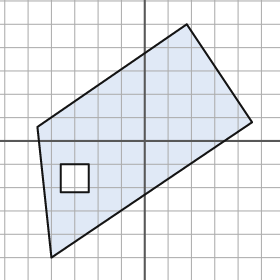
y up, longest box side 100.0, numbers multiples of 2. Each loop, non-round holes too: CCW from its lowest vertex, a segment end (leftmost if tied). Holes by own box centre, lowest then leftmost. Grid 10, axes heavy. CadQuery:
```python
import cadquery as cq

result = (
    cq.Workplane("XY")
    .moveTo(-40.0, -50.0)
    .lineTo(46.0, 8.0)
    .lineTo(18.0, 50.0)
    .lineTo(-46.0, 6.0)
    .close()
    .moveTo(-36.0, -22.0)
    .lineTo(-24.0, -22.0)
    .lineTo(-24.0, -10.0)
    .lineTo(-36.0, -10.0)
    .close()
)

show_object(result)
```